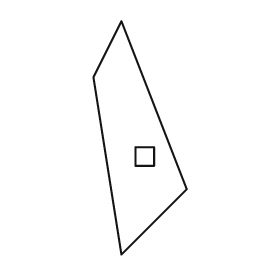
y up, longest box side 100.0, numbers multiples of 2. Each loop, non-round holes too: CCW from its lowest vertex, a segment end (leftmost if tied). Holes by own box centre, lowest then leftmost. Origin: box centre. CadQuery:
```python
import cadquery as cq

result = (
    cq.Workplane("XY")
    .moveTo(-8.0, -50.0)
    .lineTo(20.0, -22.0)
    .lineTo(-8.0, 50.0)
    .lineTo(-20.0, 26.0)
    .close()
    .moveTo(-2.0, -12.0)
    .lineTo(6.0, -12.0)
    .lineTo(6.0, -4.0)
    .lineTo(-2.0, -4.0)
    .close()
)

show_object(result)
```